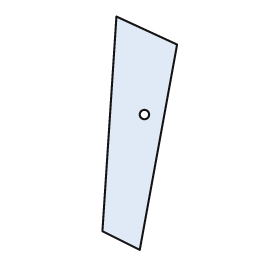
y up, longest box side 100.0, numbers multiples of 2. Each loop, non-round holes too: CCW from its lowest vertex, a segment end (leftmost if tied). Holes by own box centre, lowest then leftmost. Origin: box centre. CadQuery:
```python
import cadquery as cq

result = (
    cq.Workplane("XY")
    .moveTo(0.0, -50.0)
    .lineTo(16.0, 38.0)
    .lineTo(-10.0, 50.0)
    .lineTo(-16.0, -42.0)
    .close()
    .moveTo(2.0, 8.0)
    .circle(2.0)
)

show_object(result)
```